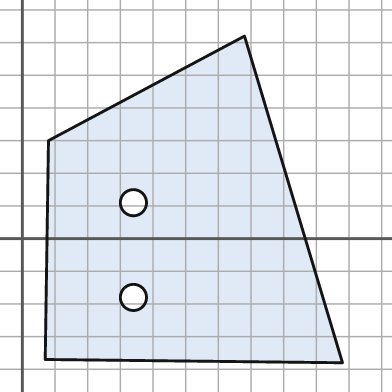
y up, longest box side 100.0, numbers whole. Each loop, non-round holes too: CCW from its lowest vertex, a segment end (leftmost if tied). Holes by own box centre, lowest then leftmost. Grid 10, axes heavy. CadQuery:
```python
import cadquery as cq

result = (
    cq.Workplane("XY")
    .moveTo(98.0, -38.0)
    .lineTo(68.0, 62.0)
    .lineTo(8.0, 30.0)
    .lineTo(7.0, -37.0)
    .close()
    .moveTo(34.0, -18.0)
    .circle(4.0)
    .moveTo(34.0, 11.0)
    .circle(4.0)
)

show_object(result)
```